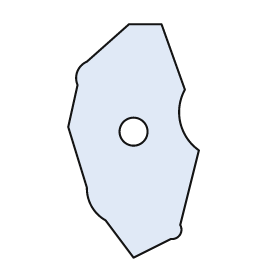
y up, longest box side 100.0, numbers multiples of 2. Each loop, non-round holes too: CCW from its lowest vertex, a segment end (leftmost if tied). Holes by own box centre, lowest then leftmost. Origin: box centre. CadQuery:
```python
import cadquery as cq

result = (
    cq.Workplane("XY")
    .moveTo(0.0, -50.0)
    .lineTo(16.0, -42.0)
    .threePointArc((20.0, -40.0), (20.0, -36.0))
    .lineTo(28.0, -4.0)
    .threePointArc((20.0, 8.0), (22.0, 22.0))
    .lineTo(12.0, 50.0)
    .lineTo(-2.0, 50.0)
    .lineTo(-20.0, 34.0)
    .threePointArc((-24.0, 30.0), (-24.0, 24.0))
    .lineTo(-28.0, 6.0)
    .lineTo(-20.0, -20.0)
    .threePointArc((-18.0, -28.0), (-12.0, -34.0))
    .close()
    .moveTo(0.0, 4.0)
    .circle(6.0)
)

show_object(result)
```